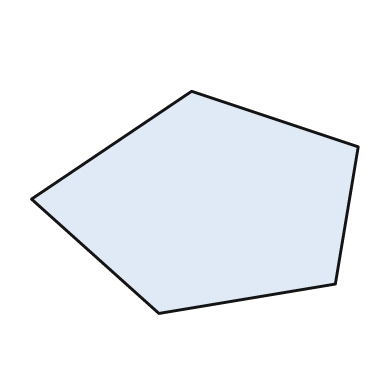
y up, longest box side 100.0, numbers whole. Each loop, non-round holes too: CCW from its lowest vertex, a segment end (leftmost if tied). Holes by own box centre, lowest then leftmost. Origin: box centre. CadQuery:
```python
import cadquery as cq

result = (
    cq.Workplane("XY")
    .moveTo(-11.0, -34.0)
    .lineTo(43.0, -25.0)
    .lineTo(50.0, 17.0)
    .lineTo(-1.0, 34.0)
    .lineTo(-50.0, 1.0)
    .close()
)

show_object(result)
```